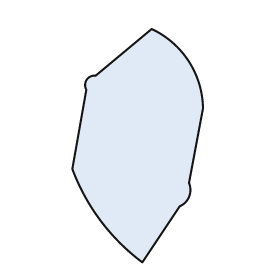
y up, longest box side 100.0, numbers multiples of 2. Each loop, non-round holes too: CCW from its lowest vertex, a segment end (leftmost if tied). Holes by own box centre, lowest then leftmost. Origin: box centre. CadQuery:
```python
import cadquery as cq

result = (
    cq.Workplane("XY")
    .moveTo(2.0, -50.0)
    .lineTo(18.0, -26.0)
    .threePointArc((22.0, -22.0), (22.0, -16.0))
    .lineTo(28.0, 16.0)
    .threePointArc((22.0, 36.0), (6.0, 50.0))
    .lineTo(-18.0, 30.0)
    .threePointArc((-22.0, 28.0), (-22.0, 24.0))
    .lineTo(-28.0, -10.0)
    .threePointArc((-16.0, -32.0), (2.0, -50.0))
    .close()
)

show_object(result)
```